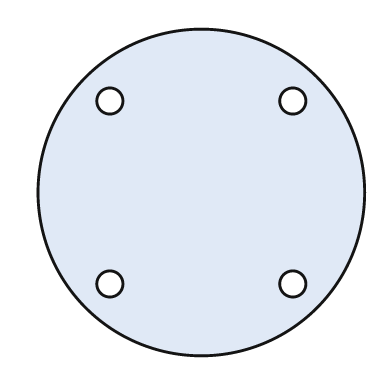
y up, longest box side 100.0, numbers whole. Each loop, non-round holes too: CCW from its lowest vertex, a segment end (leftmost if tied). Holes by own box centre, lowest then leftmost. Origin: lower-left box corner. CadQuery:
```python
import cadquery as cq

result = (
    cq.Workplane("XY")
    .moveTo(50.0, 50.0)
    .circle(50.0)
    .moveTo(22.0, 22.0)
    .circle(4.0)
    .moveTo(78.0, 22.0)
    .circle(4.0)
    .moveTo(22.0, 78.0)
    .circle(4.0)
    .moveTo(78.0, 78.0)
    .circle(4.0)
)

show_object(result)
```